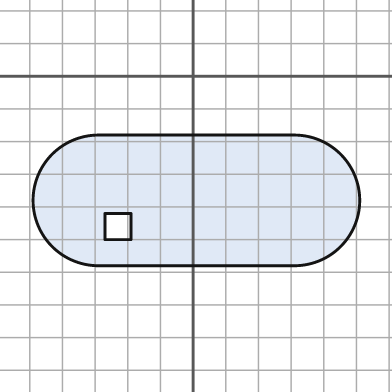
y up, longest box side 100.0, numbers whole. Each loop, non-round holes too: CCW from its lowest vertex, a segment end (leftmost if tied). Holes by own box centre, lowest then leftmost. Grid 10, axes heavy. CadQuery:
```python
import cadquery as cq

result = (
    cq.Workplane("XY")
    .moveTo(-29.0, -58.0)
    .lineTo(31.0, -58.0)
    .threePointArc((51.0, -38.0), (31.0, -18.0))
    .lineTo(-29.0, -18.0)
    .threePointArc((-49.0, -38.0), (-29.0, -58.0))
    .close()
    .moveTo(-27.0, -50.0)
    .lineTo(-19.0, -50.0)
    .lineTo(-19.0, -42.0)
    .lineTo(-27.0, -42.0)
    .close()
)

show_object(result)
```